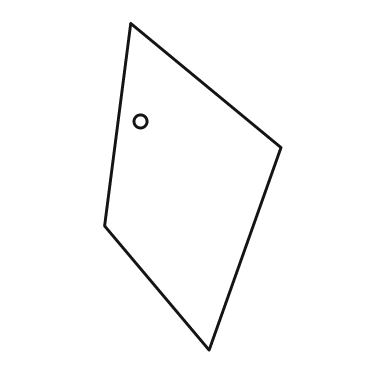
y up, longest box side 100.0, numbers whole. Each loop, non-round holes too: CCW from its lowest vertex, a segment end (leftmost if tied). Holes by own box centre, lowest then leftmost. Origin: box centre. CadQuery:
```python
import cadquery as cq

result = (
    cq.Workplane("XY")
    .moveTo(5.0, -50.0)
    .lineTo(27.0, 12.0)
    .lineTo(-19.0, 50.0)
    .lineTo(-27.0, -12.0)
    .close()
    .moveTo(-16.0, 20.0)
    .circle(2.0)
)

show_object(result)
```